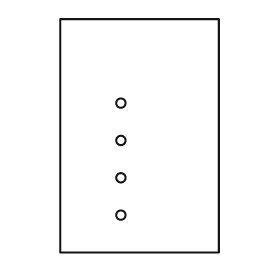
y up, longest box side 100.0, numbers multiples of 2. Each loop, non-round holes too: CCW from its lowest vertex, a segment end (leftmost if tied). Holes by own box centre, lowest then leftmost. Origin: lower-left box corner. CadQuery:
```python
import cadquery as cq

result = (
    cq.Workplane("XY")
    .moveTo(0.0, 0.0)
    .lineTo(68.0, 0.0)
    .lineTo(68.0, 100.0)
    .lineTo(0.0, 100.0)
    .close()
    .moveTo(26.0, 16.0)
    .circle(2.0)
    .moveTo(26.0, 32.0)
    .circle(2.0)
    .moveTo(26.0, 48.0)
    .circle(2.0)
    .moveTo(26.0, 64.0)
    .circle(2.0)
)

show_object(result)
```